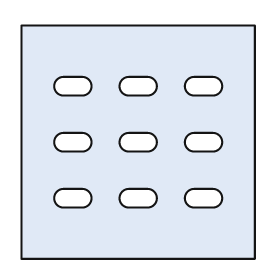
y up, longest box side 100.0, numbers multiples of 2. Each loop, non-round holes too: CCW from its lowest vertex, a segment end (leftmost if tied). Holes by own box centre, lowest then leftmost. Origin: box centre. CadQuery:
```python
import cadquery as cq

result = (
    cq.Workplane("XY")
    .moveTo(-50.0, -50.0)
    .lineTo(50.0, -50.0)
    .lineTo(50.0, 50.0)
    .lineTo(-50.0, 50.0)
    .close()
    .moveTo(-32.0, -28.0)
    .lineTo(-24.0, -28.0)
    .threePointArc((-20.0, -24.0), (-24.0, -20.0))
    .lineTo(-32.0, -20.0)
    .threePointArc((-36.0, -24.0), (-32.0, -28.0))
    .close()
    .moveTo(-4.0, -28.0)
    .lineTo(4.0, -28.0)
    .threePointArc((8.0, -24.0), (4.0, -20.0))
    .lineTo(-4.0, -20.0)
    .threePointArc((-8.0, -24.0), (-4.0, -28.0))
    .close()
    .moveTo(24.0, -28.0)
    .lineTo(32.0, -28.0)
    .threePointArc((36.0, -24.0), (32.0, -20.0))
    .lineTo(24.0, -20.0)
    .threePointArc((20.0, -24.0), (24.0, -28.0))
    .close()
    .moveTo(-32.0, -4.0)
    .lineTo(-24.0, -4.0)
    .threePointArc((-20.0, 0.0), (-24.0, 4.0))
    .lineTo(-32.0, 4.0)
    .threePointArc((-36.0, 0.0), (-32.0, -4.0))
    .close()
    .moveTo(-4.0, -4.0)
    .lineTo(4.0, -4.0)
    .threePointArc((8.0, 0.0), (4.0, 4.0))
    .lineTo(-4.0, 4.0)
    .threePointArc((-8.0, 0.0), (-4.0, -4.0))
    .close()
    .moveTo(24.0, -4.0)
    .lineTo(32.0, -4.0)
    .threePointArc((36.0, 0.0), (32.0, 4.0))
    .lineTo(24.0, 4.0)
    .threePointArc((20.0, 0.0), (24.0, -4.0))
    .close()
    .moveTo(-32.0, 20.0)
    .lineTo(-24.0, 20.0)
    .threePointArc((-20.0, 24.0), (-24.0, 28.0))
    .lineTo(-32.0, 28.0)
    .threePointArc((-36.0, 24.0), (-32.0, 20.0))
    .close()
    .moveTo(-4.0, 20.0)
    .lineTo(4.0, 20.0)
    .threePointArc((8.0, 24.0), (4.0, 28.0))
    .lineTo(-4.0, 28.0)
    .threePointArc((-8.0, 24.0), (-4.0, 20.0))
    .close()
    .moveTo(24.0, 20.0)
    .lineTo(32.0, 20.0)
    .threePointArc((36.0, 24.0), (32.0, 28.0))
    .lineTo(24.0, 28.0)
    .threePointArc((20.0, 24.0), (24.0, 20.0))
    .close()
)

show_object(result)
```